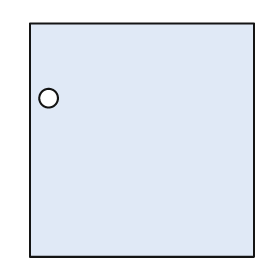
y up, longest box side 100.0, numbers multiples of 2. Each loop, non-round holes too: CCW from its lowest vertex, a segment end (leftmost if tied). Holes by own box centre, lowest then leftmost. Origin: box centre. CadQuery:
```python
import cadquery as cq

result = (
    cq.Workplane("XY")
    .moveTo(-48.0, -50.0)
    .lineTo(48.0, -50.0)
    .lineTo(48.0, 50.0)
    .lineTo(-48.0, 50.0)
    .close()
    .moveTo(-40.0, 18.0)
    .circle(4.0)
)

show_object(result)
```